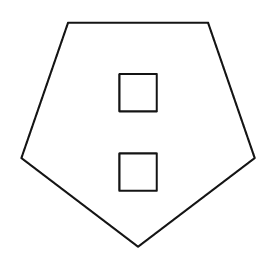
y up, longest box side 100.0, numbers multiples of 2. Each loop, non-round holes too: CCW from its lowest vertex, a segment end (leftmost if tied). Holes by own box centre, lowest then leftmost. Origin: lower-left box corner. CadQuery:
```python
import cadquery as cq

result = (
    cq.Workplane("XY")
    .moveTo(50.0, 0.0)
    .lineTo(100.0, 38.0)
    .lineTo(80.0, 96.0)
    .lineTo(20.0, 96.0)
    .lineTo(0.0, 38.0)
    .close()
    .moveTo(42.0, 24.0)
    .lineTo(58.0, 24.0)
    .lineTo(58.0, 40.0)
    .lineTo(42.0, 40.0)
    .close()
    .moveTo(42.0, 58.0)
    .lineTo(58.0, 58.0)
    .lineTo(58.0, 74.0)
    .lineTo(42.0, 74.0)
    .close()
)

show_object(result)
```